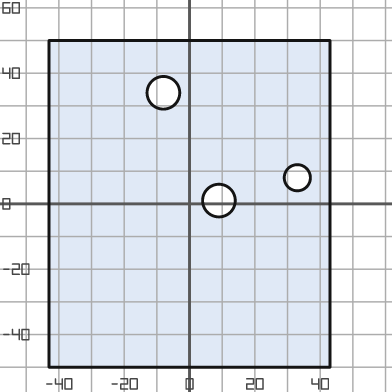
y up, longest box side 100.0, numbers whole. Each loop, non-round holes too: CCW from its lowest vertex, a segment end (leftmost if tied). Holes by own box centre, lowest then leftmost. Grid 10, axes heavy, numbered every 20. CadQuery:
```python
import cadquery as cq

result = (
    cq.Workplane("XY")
    .moveTo(-43.0, -50.0)
    .lineTo(43.0, -50.0)
    .lineTo(43.0, 50.0)
    .lineTo(-43.0, 50.0)
    .close()
    .moveTo(9.0, 1.0)
    .circle(5.0)
    .moveTo(33.0, 8.0)
    .circle(4.0)
    .moveTo(-8.0, 34.0)
    .circle(5.0)
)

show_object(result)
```